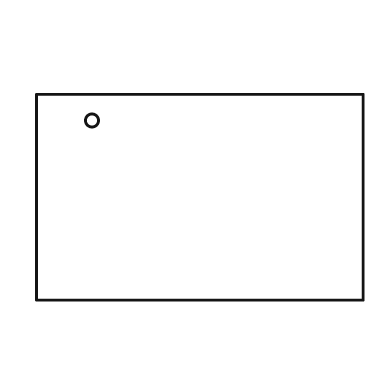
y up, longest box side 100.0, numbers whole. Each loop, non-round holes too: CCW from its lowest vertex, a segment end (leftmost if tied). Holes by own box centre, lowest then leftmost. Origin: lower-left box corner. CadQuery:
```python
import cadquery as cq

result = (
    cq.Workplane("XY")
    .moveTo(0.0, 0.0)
    .lineTo(100.0, 0.0)
    .lineTo(100.0, 63.0)
    .lineTo(0.0, 63.0)
    .close()
    .moveTo(17.0, 55.0)
    .circle(2.0)
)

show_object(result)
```